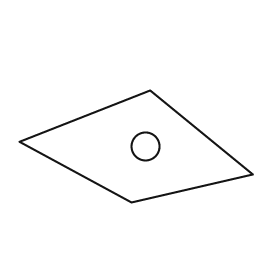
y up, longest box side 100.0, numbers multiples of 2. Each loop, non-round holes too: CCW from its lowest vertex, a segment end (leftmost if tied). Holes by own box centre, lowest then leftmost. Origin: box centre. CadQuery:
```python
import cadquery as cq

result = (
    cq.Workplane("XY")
    .moveTo(-2.0, -24.0)
    .lineTo(50.0, -12.0)
    .lineTo(6.0, 24.0)
    .lineTo(-50.0, 2.0)
    .close()
    .moveTo(4.0, 0.0)
    .circle(6.0)
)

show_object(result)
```